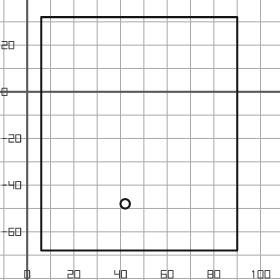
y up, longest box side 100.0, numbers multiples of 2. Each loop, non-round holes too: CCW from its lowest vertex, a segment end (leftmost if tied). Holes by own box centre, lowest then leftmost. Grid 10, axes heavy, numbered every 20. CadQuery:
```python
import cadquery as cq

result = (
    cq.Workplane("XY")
    .moveTo(6.0, -68.0)
    .lineTo(90.0, -68.0)
    .lineTo(90.0, 32.0)
    .lineTo(6.0, 32.0)
    .close()
    .moveTo(42.0, -48.0)
    .circle(2.0)
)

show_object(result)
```